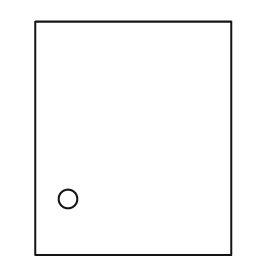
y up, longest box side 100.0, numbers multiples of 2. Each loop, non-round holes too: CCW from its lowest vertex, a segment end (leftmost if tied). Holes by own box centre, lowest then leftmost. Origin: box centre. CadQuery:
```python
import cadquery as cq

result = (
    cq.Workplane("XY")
    .moveTo(-42.0, -50.0)
    .lineTo(42.0, -50.0)
    .lineTo(42.0, 50.0)
    .lineTo(-42.0, 50.0)
    .close()
    .moveTo(-28.0, -26.0)
    .circle(4.0)
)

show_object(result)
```